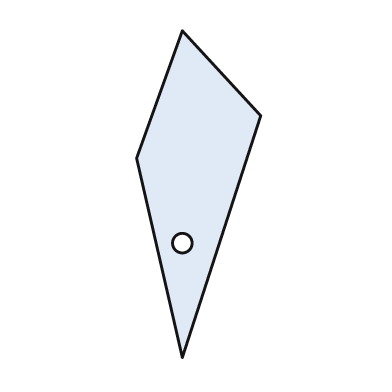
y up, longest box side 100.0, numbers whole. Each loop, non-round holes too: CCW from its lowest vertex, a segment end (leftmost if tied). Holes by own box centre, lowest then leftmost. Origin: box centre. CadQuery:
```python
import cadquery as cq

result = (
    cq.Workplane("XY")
    .moveTo(-5.0, -50.0)
    .lineTo(19.0, 24.0)
    .lineTo(-5.0, 50.0)
    .lineTo(-19.0, 11.0)
    .close()
    .moveTo(-5.0, -15.0)
    .circle(3.0)
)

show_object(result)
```